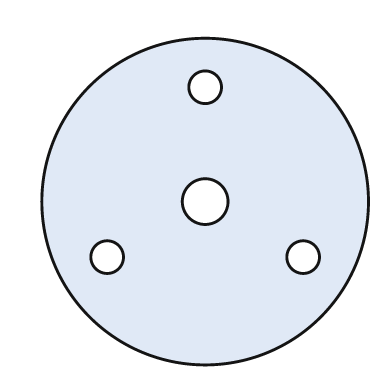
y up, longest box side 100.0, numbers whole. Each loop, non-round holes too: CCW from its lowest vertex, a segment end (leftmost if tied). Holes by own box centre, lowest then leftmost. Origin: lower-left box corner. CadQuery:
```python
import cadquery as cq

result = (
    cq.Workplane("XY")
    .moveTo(50.0, 50.0)
    .circle(50.0)
    .moveTo(20.0, 33.0)
    .circle(5.0)
    .moveTo(80.0, 33.0)
    .circle(5.0)
    .moveTo(50.0, 50.0)
    .circle(7.0)
    .moveTo(50.0, 85.0)
    .circle(5.0)
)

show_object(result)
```